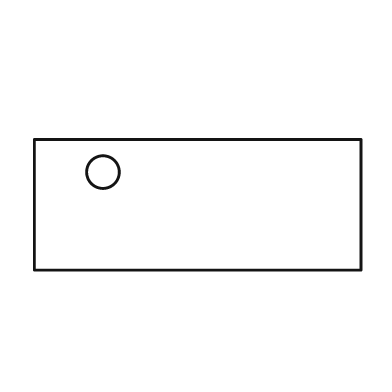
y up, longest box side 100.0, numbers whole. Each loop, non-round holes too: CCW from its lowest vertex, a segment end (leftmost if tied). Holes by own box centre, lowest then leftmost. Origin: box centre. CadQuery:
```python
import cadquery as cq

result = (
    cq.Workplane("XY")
    .moveTo(-50.0, -20.0)
    .lineTo(50.0, -20.0)
    .lineTo(50.0, 20.0)
    .lineTo(-50.0, 20.0)
    .close()
    .moveTo(-29.0, 10.0)
    .circle(5.0)
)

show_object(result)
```